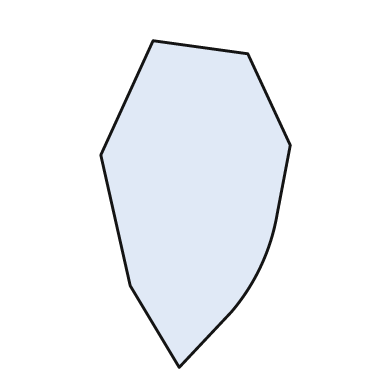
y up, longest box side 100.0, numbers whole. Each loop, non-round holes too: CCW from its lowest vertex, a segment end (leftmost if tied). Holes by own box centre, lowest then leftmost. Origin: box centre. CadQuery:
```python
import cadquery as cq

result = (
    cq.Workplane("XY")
    .moveTo(-5.0, -50.0)
    .lineTo(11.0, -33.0)
    .threePointArc((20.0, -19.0), (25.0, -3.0))
    .lineTo(29.0, 18.0)
    .lineTo(16.0, 46.0)
    .lineTo(-13.0, 50.0)
    .lineTo(-29.0, 15.0)
    .lineTo(-20.0, -25.0)
    .close()
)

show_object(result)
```